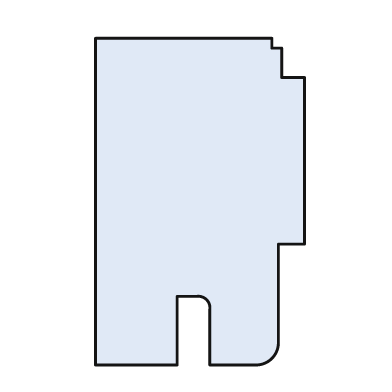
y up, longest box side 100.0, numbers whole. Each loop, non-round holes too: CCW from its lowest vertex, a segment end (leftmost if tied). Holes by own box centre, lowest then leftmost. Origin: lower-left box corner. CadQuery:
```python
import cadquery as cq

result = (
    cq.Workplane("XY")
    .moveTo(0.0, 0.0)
    .lineTo(25.0, 0.0)
    .lineTo(25.0, 21.0)
    .lineTo(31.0, 21.0)
    .threePointArc((34.0, 20.0), (35.0, 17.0))
    .lineTo(35.0, 0.0)
    .lineTo(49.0, 0.0)
    .threePointArc((54.0, 2.0), (56.0, 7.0))
    .lineTo(56.0, 37.0)
    .lineTo(64.0, 37.0)
    .lineTo(64.0, 88.0)
    .lineTo(57.0, 88.0)
    .lineTo(57.0, 97.0)
    .lineTo(54.0, 97.0)
    .lineTo(54.0, 100.0)
    .lineTo(0.0, 100.0)
    .close()
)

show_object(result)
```